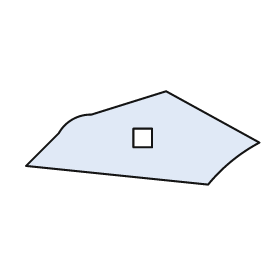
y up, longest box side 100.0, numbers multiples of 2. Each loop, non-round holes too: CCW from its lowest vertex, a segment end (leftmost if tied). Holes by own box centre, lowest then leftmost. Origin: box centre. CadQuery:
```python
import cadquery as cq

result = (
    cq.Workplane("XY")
    .moveTo(28.0, -20.0)
    .threePointArc((38.0, -10.0), (50.0, -2.0))
    .lineTo(10.0, 20.0)
    .lineTo(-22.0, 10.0)
    .threePointArc((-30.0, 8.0), (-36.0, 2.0))
    .lineTo(-50.0, -12.0)
    .close()
    .moveTo(-4.0, -4.0)
    .lineTo(4.0, -4.0)
    .lineTo(4.0, 4.0)
    .lineTo(-4.0, 4.0)
    .close()
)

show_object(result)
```